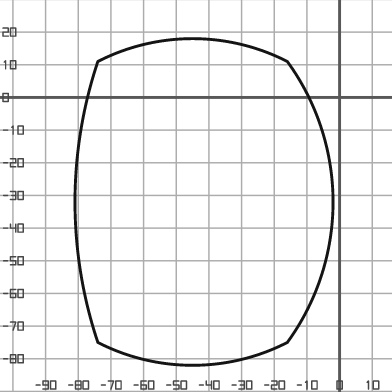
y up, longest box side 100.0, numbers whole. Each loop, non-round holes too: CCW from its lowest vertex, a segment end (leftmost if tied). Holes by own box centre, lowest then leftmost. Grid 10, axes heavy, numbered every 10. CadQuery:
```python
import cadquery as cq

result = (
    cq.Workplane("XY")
    .moveTo(-74.0, -75.0)
    .threePointArc((-45.0, -82.0), (-16.0, -75.0))
    .threePointArc((-2.0, -32.0), (-16.0, 11.0))
    .threePointArc((-45.0, 18.0), (-74.0, 11.0))
    .threePointArc((-81.0, -32.0), (-74.0, -75.0))
    .close()
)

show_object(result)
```